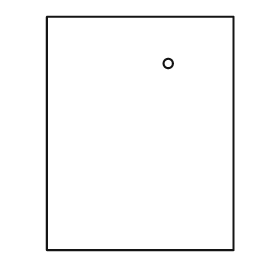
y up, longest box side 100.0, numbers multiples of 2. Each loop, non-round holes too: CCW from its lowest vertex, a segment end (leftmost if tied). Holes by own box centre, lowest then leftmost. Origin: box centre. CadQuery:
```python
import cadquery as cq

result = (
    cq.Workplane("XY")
    .moveTo(-40.0, -50.0)
    .lineTo(40.0, -50.0)
    .lineTo(40.0, 50.0)
    .lineTo(-40.0, 50.0)
    .close()
    .moveTo(12.0, 30.0)
    .circle(2.0)
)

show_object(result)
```